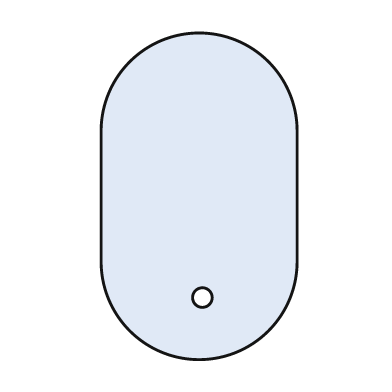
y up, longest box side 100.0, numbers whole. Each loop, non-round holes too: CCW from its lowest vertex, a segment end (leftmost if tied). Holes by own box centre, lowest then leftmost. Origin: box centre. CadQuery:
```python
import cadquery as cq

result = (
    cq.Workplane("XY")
    .moveTo(-30.0, -20.0)
    .threePointArc((0.0, -50.0), (30.0, -20.0))
    .lineTo(30.0, 20.0)
    .threePointArc((0.0, 50.0), (-30.0, 20.0))
    .close()
    .moveTo(1.0, -31.0)
    .circle(3.0)
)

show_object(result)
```